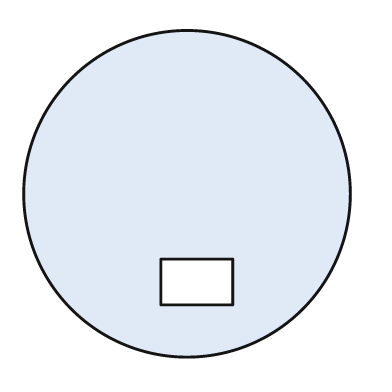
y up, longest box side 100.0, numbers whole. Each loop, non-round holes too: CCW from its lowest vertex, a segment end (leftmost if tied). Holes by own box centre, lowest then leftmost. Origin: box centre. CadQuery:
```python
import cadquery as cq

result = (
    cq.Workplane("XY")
    .moveTo(0.0, 0.0)
    .circle(50.0)
    .moveTo(-8.0, -34.0)
    .lineTo(14.0, -34.0)
    .lineTo(14.0, -20.0)
    .lineTo(-8.0, -20.0)
    .close()
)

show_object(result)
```